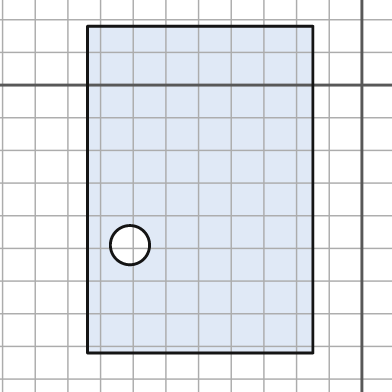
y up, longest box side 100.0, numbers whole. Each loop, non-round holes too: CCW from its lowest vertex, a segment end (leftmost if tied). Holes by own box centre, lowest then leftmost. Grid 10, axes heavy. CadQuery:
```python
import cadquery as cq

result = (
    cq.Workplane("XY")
    .moveTo(-84.0, -82.0)
    .lineTo(-15.0, -82.0)
    .lineTo(-15.0, 18.0)
    .lineTo(-84.0, 18.0)
    .close()
    .moveTo(-71.0, -49.0)
    .circle(6.0)
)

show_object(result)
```